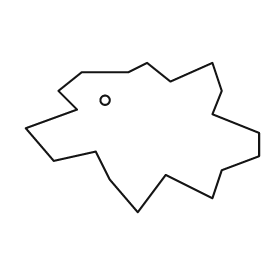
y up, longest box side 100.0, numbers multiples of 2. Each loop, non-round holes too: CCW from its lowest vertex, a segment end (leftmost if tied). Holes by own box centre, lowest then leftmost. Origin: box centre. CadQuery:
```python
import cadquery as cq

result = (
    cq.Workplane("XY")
    .moveTo(-2.0, -32.0)
    .lineTo(10.0, -16.0)
    .lineTo(30.0, -26.0)
    .lineTo(34.0, -14.0)
    .lineTo(50.0, -8.0)
    .lineTo(50.0, 2.0)
    .lineTo(30.0, 10.0)
    .lineTo(34.0, 20.0)
    .lineTo(30.0, 32.0)
    .lineTo(12.0, 24.0)
    .lineTo(2.0, 32.0)
    .lineTo(-6.0, 28.0)
    .lineTo(-26.0, 28.0)
    .lineTo(-36.0, 20.0)
    .lineTo(-28.0, 12.0)
    .lineTo(-50.0, 4.0)
    .lineTo(-38.0, -10.0)
    .lineTo(-20.0, -6.0)
    .lineTo(-14.0, -18.0)
    .close()
    .moveTo(-16.0, 16.0)
    .circle(2.0)
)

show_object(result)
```